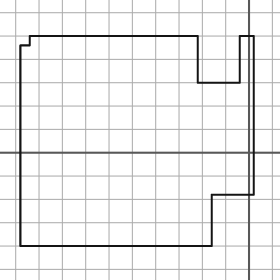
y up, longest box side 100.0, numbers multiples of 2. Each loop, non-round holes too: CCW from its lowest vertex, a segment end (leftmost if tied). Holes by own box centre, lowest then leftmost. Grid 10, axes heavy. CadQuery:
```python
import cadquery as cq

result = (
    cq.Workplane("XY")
    .moveTo(-98.0, -40.0)
    .lineTo(-16.0, -40.0)
    .lineTo(-16.0, -18.0)
    .lineTo(2.0, -18.0)
    .lineTo(2.0, 50.0)
    .lineTo(-4.0, 50.0)
    .lineTo(-4.0, 30.0)
    .lineTo(-22.0, 30.0)
    .lineTo(-22.0, 50.0)
    .lineTo(-94.0, 50.0)
    .lineTo(-94.0, 46.0)
    .lineTo(-98.0, 46.0)
    .close()
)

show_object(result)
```